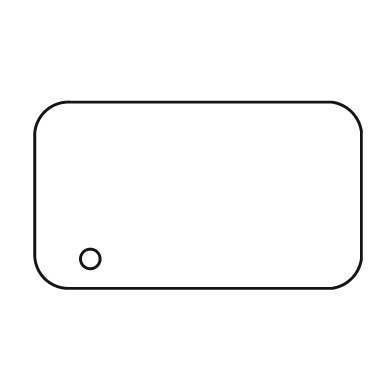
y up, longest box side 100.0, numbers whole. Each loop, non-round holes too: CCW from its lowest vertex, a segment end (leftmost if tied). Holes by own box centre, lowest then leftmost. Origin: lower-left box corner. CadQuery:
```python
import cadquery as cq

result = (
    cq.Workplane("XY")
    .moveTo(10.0, 0.0)
    .lineTo(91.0, 0.0)
    .threePointArc((97.0, 3.0), (100.0, 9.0))
    .lineTo(100.0, 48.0)
    .threePointArc((97.0, 54.0), (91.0, 57.0))
    .lineTo(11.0, 57.0)
    .threePointArc((3.0, 54.0), (0.0, 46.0))
    .lineTo(0.0, 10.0)
    .threePointArc((3.0, 3.0), (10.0, 0.0))
    .close()
    .moveTo(17.0, 9.0)
    .circle(3.0)
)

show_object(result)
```